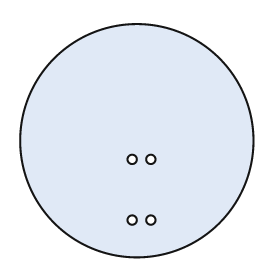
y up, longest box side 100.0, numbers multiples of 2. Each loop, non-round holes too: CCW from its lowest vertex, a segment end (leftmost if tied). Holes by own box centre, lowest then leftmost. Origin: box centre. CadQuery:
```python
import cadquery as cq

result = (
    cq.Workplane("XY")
    .moveTo(0.0, 0.0)
    .circle(50.0)
    .moveTo(-2.0, -34.0)
    .circle(2.0)
    .moveTo(6.0, -34.0)
    .circle(2.0)
    .moveTo(-2.0, -8.0)
    .circle(2.0)
    .moveTo(6.0, -8.0)
    .circle(2.0)
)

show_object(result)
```